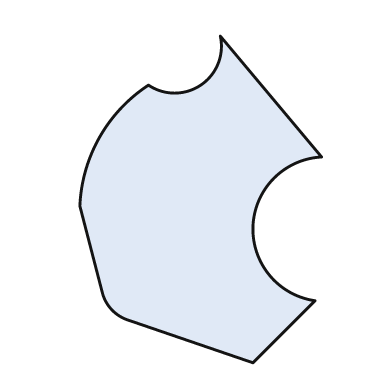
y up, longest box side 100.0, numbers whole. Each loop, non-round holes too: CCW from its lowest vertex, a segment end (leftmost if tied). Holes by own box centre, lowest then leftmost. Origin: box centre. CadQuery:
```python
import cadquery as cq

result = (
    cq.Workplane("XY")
    .moveTo(16.0, -50.0)
    .lineTo(35.0, -31.0)
    .threePointArc((16.0, -8.0), (37.0, 13.0))
    .lineTo(6.0, 50.0)
    .threePointArc((0.0, 35.0), (-16.0, 35.0))
    .threePointArc((-31.0, 19.0), (-37.0, -2.0))
    .lineTo(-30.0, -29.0)
    .threePointArc((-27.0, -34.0), (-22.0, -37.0))
    .close()
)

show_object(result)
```